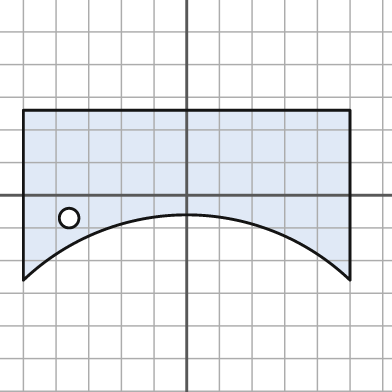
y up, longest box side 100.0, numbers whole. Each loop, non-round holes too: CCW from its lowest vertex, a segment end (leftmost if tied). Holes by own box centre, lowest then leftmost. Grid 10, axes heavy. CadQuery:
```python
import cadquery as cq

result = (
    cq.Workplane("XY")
    .moveTo(-50.0, -26.0)
    .threePointArc((0.0, -6.0), (50.0, -26.0))
    .lineTo(50.0, 26.0)
    .lineTo(-50.0, 26.0)
    .close()
    .moveTo(-36.0, -7.0)
    .circle(3.0)
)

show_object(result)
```